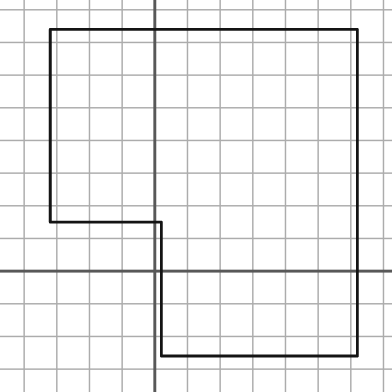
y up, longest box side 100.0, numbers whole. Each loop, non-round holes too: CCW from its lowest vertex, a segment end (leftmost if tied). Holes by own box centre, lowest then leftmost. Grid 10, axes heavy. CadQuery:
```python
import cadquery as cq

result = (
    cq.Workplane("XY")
    .moveTo(2.0, -26.0)
    .lineTo(62.0, -26.0)
    .lineTo(62.0, 74.0)
    .lineTo(-32.0, 74.0)
    .lineTo(-32.0, 15.0)
    .lineTo(2.0, 15.0)
    .close()
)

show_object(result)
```